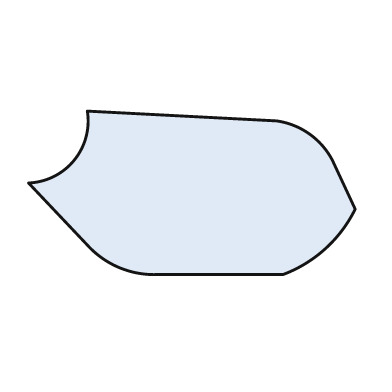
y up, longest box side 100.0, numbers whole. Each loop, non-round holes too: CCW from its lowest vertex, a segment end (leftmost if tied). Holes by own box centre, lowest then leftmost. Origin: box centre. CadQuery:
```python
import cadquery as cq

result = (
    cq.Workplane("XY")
    .moveTo(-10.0, -25.0)
    .lineTo(28.0, -25.0)
    .threePointArc((41.0, -17.0), (50.0, -5.0))
    .lineTo(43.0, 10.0)
    .threePointArc((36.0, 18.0), (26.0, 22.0))
    .lineTo(-32.0, 25.0)
    .threePointArc((-36.0, 10.0), (-50.0, 3.0))
    .lineTo(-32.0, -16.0)
    .threePointArc((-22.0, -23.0), (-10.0, -25.0))
    .close()
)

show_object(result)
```